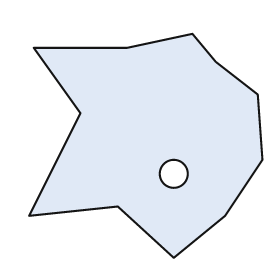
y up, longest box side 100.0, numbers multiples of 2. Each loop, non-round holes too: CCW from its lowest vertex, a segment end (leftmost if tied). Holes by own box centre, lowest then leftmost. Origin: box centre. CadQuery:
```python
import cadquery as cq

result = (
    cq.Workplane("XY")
    .moveTo(12.0, -48.0)
    .lineTo(34.0, -30.0)
    .lineTo(50.0, -6.0)
    .lineTo(48.0, 22.0)
    .lineTo(30.0, 36.0)
    .lineTo(20.0, 48.0)
    .lineTo(-8.0, 42.0)
    .lineTo(-48.0, 42.0)
    .lineTo(-28.0, 14.0)
    .lineTo(-50.0, -30.0)
    .lineTo(-12.0, -26.0)
    .close()
    .moveTo(12.0, -12.0)
    .circle(6.0)
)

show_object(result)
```